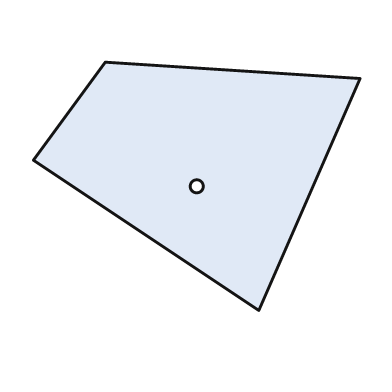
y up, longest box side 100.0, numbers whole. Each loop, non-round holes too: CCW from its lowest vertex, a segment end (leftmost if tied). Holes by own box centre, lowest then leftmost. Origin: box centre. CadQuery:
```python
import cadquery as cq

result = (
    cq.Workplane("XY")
    .moveTo(19.0, -38.0)
    .lineTo(50.0, 33.0)
    .lineTo(-28.0, 38.0)
    .lineTo(-50.0, 8.0)
    .close()
    .moveTo(0.0, 0.0)
    .circle(2.0)
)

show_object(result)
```